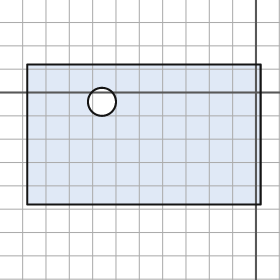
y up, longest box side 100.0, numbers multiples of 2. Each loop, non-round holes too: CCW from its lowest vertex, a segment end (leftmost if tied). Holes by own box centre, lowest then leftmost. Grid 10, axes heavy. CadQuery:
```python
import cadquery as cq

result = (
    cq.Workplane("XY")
    .moveTo(-98.0, -48.0)
    .lineTo(2.0, -48.0)
    .lineTo(2.0, 12.0)
    .lineTo(-98.0, 12.0)
    .close()
    .moveTo(-66.0, -4.0)
    .circle(6.0)
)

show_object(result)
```